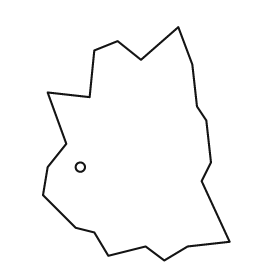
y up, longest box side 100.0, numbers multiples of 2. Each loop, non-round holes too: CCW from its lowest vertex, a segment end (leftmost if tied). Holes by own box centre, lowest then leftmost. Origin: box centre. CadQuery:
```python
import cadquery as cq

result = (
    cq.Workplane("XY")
    .moveTo(12.0, -50.0)
    .lineTo(22.0, -44.0)
    .lineTo(40.0, -42.0)
    .lineTo(28.0, -16.0)
    .lineTo(32.0, -8.0)
    .lineTo(30.0, 10.0)
    .lineTo(26.0, 16.0)
    .lineTo(24.0, 34.0)
    .lineTo(18.0, 50.0)
    .lineTo(2.0, 36.0)
    .lineTo(-8.0, 44.0)
    .lineTo(-18.0, 40.0)
    .lineTo(-20.0, 20.0)
    .lineTo(-38.0, 22.0)
    .lineTo(-30.0, 0.0)
    .lineTo(-38.0, -10.0)
    .lineTo(-40.0, -22.0)
    .lineTo(-26.0, -36.0)
    .lineTo(-18.0, -38.0)
    .lineTo(-12.0, -48.0)
    .lineTo(4.0, -44.0)
    .close()
    .moveTo(-24.0, -10.0)
    .circle(2.0)
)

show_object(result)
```